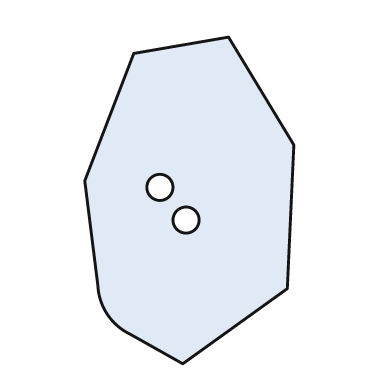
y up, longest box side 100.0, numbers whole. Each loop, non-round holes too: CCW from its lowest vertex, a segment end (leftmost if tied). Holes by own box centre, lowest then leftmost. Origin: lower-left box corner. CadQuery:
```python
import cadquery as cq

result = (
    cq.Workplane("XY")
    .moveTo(30.0, 0.0)
    .lineTo(62.0, 23.0)
    .lineTo(64.0, 67.0)
    .lineTo(44.0, 100.0)
    .lineTo(15.0, 95.0)
    .lineTo(0.0, 56.0)
    .lineTo(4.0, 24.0)
    .threePointArc((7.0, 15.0), (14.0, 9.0))
    .close()
    .moveTo(31.0, 44.0)
    .circle(4.0)
    .moveTo(23.0, 54.0)
    .circle(4.0)
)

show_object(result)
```